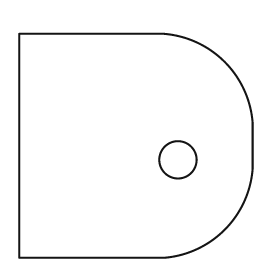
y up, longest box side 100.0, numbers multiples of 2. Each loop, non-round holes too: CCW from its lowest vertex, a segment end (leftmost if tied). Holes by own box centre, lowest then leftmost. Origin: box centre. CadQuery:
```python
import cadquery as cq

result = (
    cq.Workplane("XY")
    .moveTo(-50.0, -48.0)
    .lineTo(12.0, -48.0)
    .threePointArc((38.0, -36.0), (50.0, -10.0))
    .lineTo(50.0, 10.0)
    .threePointArc((38.0, 36.0), (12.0, 48.0))
    .lineTo(-50.0, 48.0)
    .close()
    .moveTo(18.0, -6.0)
    .circle(8.0)
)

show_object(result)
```